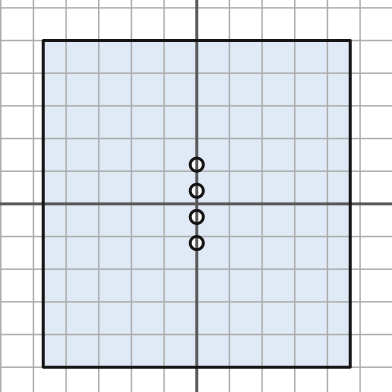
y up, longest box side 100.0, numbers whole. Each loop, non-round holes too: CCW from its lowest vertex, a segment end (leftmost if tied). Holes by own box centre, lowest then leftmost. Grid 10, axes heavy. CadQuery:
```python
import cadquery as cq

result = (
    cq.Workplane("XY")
    .moveTo(-47.0, -50.0)
    .lineTo(47.0, -50.0)
    .lineTo(47.0, 50.0)
    .lineTo(-47.0, 50.0)
    .close()
    .moveTo(0.0, -12.0)
    .circle(2.0)
    .moveTo(0.0, -4.0)
    .circle(2.0)
    .moveTo(0.0, 4.0)
    .circle(2.0)
    .moveTo(0.0, 12.0)
    .circle(2.0)
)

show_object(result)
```